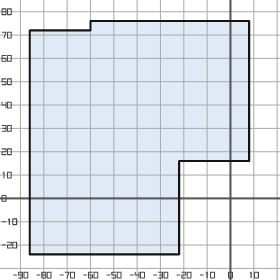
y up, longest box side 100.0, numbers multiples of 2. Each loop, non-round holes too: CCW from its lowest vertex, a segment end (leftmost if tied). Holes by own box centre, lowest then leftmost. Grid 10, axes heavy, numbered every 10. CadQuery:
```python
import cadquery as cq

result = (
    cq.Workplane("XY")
    .moveTo(-86.0, -24.0)
    .lineTo(-22.0, -24.0)
    .lineTo(-22.0, 16.0)
    .lineTo(8.0, 16.0)
    .lineTo(8.0, 76.0)
    .lineTo(-60.0, 76.0)
    .lineTo(-60.0, 72.0)
    .lineTo(-86.0, 72.0)
    .close()
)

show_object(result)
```